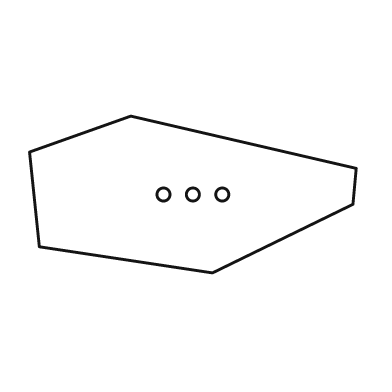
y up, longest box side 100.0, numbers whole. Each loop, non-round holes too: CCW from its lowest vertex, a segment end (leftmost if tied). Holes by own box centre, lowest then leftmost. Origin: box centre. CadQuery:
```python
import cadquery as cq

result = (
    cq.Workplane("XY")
    .moveTo(6.0, -24.0)
    .lineTo(49.0, -3.0)
    .lineTo(50.0, 8.0)
    .lineTo(-19.0, 24.0)
    .lineTo(-50.0, 13.0)
    .lineTo(-47.0, -16.0)
    .close()
    .moveTo(-9.0, 0.0)
    .circle(2.0)
    .moveTo(0.0, 0.0)
    .circle(2.0)
    .moveTo(9.0, 0.0)
    .circle(2.0)
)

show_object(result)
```